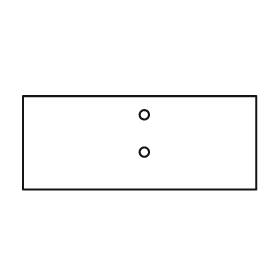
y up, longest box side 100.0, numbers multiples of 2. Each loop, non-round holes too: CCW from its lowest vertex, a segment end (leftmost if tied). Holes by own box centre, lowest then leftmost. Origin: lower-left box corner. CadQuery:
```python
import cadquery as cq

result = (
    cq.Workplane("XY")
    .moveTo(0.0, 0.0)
    .lineTo(100.0, 0.0)
    .lineTo(100.0, 40.0)
    .lineTo(0.0, 40.0)
    .close()
    .moveTo(52.0, 16.0)
    .circle(2.0)
    .moveTo(52.0, 32.0)
    .circle(2.0)
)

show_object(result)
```